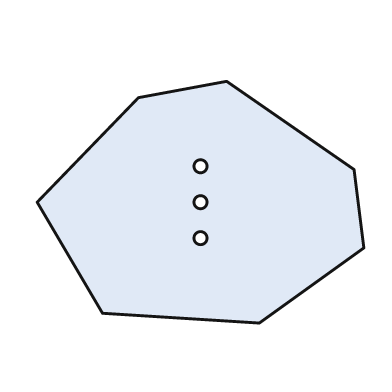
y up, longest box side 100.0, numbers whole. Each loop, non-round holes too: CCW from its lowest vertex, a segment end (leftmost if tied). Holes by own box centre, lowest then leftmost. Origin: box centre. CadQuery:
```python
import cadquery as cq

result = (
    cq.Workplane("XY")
    .moveTo(18.0, -37.0)
    .lineTo(50.0, -14.0)
    .lineTo(47.0, 10.0)
    .lineTo(8.0, 37.0)
    .lineTo(-19.0, 32.0)
    .lineTo(-50.0, 0.0)
    .lineTo(-30.0, -34.0)
    .close()
    .moveTo(0.0, -11.0)
    .circle(2.0)
    .moveTo(0.0, 0.0)
    .circle(2.0)
    .moveTo(0.0, 11.0)
    .circle(2.0)
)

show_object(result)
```